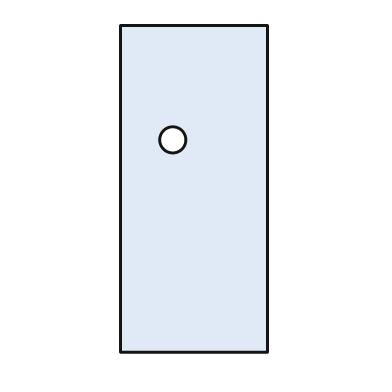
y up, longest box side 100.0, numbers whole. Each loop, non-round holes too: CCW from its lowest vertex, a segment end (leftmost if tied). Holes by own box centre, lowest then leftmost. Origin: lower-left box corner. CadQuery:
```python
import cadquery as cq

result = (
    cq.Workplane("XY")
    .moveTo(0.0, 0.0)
    .lineTo(45.0, 0.0)
    .lineTo(45.0, 100.0)
    .lineTo(0.0, 100.0)
    .close()
    .moveTo(16.0, 65.0)
    .circle(4.0)
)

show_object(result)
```